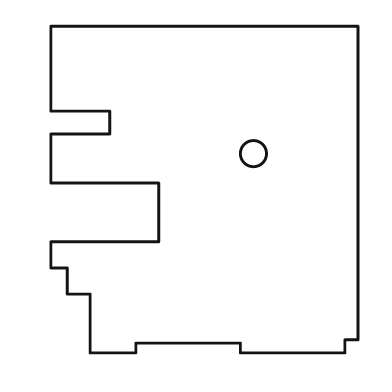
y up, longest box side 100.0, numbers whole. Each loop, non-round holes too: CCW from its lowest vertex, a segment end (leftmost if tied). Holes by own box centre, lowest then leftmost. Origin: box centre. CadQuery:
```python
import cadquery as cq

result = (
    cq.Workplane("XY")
    .moveTo(-35.0, -50.0)
    .lineTo(-21.0, -50.0)
    .lineTo(-21.0, -47.0)
    .lineTo(11.0, -47.0)
    .lineTo(11.0, -50.0)
    .lineTo(43.0, -50.0)
    .lineTo(43.0, -46.0)
    .lineTo(47.0, -46.0)
    .lineTo(47.0, 50.0)
    .lineTo(-47.0, 50.0)
    .lineTo(-47.0, 24.0)
    .lineTo(-29.0, 24.0)
    .lineTo(-29.0, 17.0)
    .lineTo(-47.0, 17.0)
    .lineTo(-47.0, 2.0)
    .lineTo(-14.0, 2.0)
    .lineTo(-14.0, -16.0)
    .lineTo(-47.0, -16.0)
    .lineTo(-47.0, -24.0)
    .lineTo(-42.0, -24.0)
    .lineTo(-42.0, -32.0)
    .lineTo(-35.0, -32.0)
    .close()
    .moveTo(15.0, 11.0)
    .circle(4.0)
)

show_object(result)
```